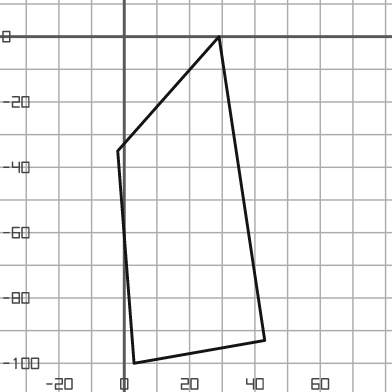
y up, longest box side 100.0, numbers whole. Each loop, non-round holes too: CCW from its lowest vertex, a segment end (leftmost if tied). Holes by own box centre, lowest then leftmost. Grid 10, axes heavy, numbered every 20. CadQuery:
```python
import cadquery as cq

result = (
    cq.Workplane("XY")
    .moveTo(3.0, -100.0)
    .lineTo(43.0, -93.0)
    .lineTo(29.0, 0.0)
    .lineTo(-2.0, -35.0)
    .close()
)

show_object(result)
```